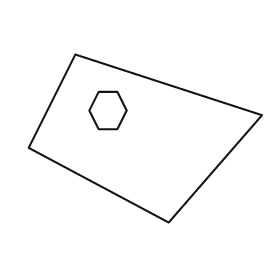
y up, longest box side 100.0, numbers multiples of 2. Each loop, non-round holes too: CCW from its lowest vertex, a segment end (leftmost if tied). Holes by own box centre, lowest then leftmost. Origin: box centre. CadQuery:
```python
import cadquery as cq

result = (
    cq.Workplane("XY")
    .moveTo(10.0, -36.0)
    .lineTo(50.0, 10.0)
    .lineTo(-30.0, 36.0)
    .lineTo(-50.0, -4.0)
    .close()
    .moveTo(-20.0, 4.0)
    .lineTo(-12.0, 4.0)
    .lineTo(-8.0, 12.0)
    .lineTo(-12.0, 20.0)
    .lineTo(-20.0, 20.0)
    .lineTo(-24.0, 12.0)
    .close()
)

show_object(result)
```